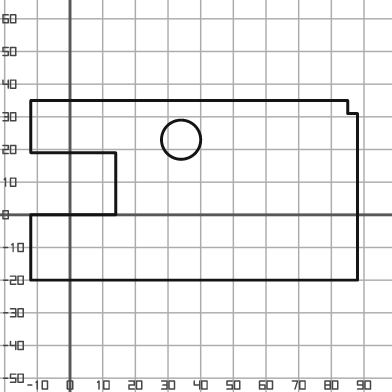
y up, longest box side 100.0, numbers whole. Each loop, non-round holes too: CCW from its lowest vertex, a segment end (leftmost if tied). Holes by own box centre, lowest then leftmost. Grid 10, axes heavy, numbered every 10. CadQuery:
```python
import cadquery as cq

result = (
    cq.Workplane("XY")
    .moveTo(-12.0, -20.0)
    .lineTo(88.0, -20.0)
    .lineTo(88.0, 31.0)
    .lineTo(85.0, 31.0)
    .lineTo(85.0, 35.0)
    .lineTo(-12.0, 35.0)
    .lineTo(-12.0, 19.0)
    .lineTo(14.0, 19.0)
    .lineTo(14.0, 0.0)
    .lineTo(-12.0, 0.0)
    .close()
    .moveTo(34.0, 23.0)
    .circle(6.0)
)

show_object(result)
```